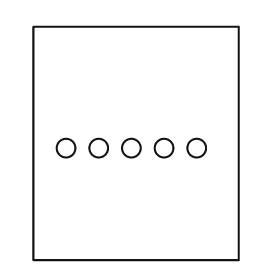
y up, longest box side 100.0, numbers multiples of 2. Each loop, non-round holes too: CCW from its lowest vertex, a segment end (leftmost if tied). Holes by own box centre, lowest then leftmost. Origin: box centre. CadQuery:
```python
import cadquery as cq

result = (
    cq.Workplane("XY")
    .moveTo(-44.0, -50.0)
    .lineTo(44.0, -50.0)
    .lineTo(44.0, 50.0)
    .lineTo(-44.0, 50.0)
    .close()
    .moveTo(-30.0, -2.0)
    .circle(4.0)
    .moveTo(-16.0, -2.0)
    .circle(4.0)
    .moveTo(-2.0, -2.0)
    .circle(4.0)
    .moveTo(12.0, -2.0)
    .circle(4.0)
    .moveTo(26.0, -2.0)
    .circle(4.0)
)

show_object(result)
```